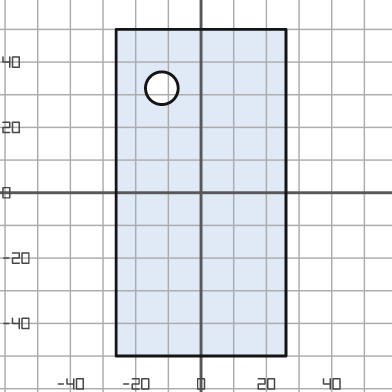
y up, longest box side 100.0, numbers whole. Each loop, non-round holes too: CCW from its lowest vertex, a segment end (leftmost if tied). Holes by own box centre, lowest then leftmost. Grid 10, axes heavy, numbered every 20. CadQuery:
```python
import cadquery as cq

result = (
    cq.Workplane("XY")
    .moveTo(-26.0, -50.0)
    .lineTo(26.0, -50.0)
    .lineTo(26.0, 50.0)
    .lineTo(-26.0, 50.0)
    .close()
    .moveTo(-12.0, 32.0)
    .circle(5.0)
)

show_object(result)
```